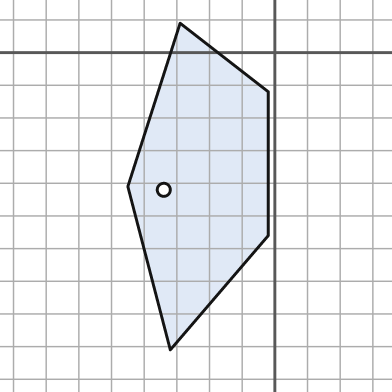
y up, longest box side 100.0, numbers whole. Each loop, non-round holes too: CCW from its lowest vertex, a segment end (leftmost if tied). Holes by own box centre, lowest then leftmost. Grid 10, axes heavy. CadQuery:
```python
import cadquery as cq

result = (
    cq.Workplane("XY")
    .moveTo(-32.0, -91.0)
    .lineTo(-2.0, -56.0)
    .lineTo(-2.0, -12.0)
    .lineTo(-29.0, 9.0)
    .lineTo(-45.0, -41.0)
    .close()
    .moveTo(-34.0, -42.0)
    .circle(2.0)
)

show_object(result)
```